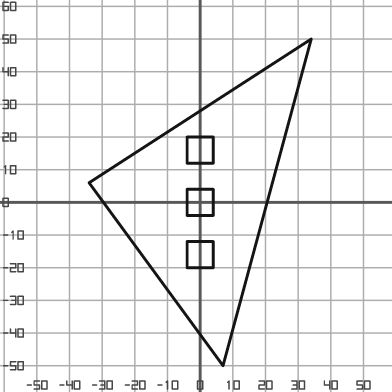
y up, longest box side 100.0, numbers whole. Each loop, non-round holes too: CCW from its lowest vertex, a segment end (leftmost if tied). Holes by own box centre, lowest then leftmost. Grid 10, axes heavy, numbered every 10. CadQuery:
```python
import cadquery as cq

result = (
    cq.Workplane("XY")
    .moveTo(7.0, -50.0)
    .lineTo(34.0, 50.0)
    .lineTo(-34.0, 6.0)
    .close()
    .moveTo(-4.0, -20.0)
    .lineTo(4.0, -20.0)
    .lineTo(4.0, -12.0)
    .lineTo(-4.0, -12.0)
    .close()
    .moveTo(-4.0, -4.0)
    .lineTo(4.0, -4.0)
    .lineTo(4.0, 4.0)
    .lineTo(-4.0, 4.0)
    .close()
    .moveTo(-4.0, 12.0)
    .lineTo(4.0, 12.0)
    .lineTo(4.0, 20.0)
    .lineTo(-4.0, 20.0)
    .close()
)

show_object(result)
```